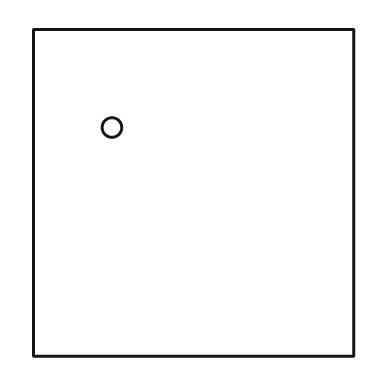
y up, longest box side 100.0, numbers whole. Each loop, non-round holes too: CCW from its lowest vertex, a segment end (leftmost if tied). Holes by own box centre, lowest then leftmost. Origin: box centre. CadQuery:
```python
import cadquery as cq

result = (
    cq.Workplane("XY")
    .moveTo(-49.0, -50.0)
    .lineTo(49.0, -50.0)
    .lineTo(49.0, 50.0)
    .lineTo(-49.0, 50.0)
    .close()
    .moveTo(-25.0, 20.0)
    .circle(3.0)
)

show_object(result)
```